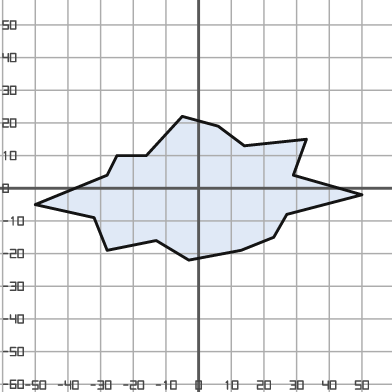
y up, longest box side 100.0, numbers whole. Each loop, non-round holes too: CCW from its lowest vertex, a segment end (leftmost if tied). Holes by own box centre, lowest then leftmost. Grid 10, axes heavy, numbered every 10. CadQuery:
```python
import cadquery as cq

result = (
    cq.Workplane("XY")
    .moveTo(-3.0, -22.0)
    .lineTo(13.0, -19.0)
    .lineTo(23.0, -15.0)
    .lineTo(27.0, -8.0)
    .lineTo(50.0, -2.0)
    .lineTo(29.0, 4.0)
    .lineTo(33.0, 15.0)
    .lineTo(14.0, 13.0)
    .lineTo(6.0, 19.0)
    .lineTo(-5.0, 22.0)
    .lineTo(-16.0, 10.0)
    .lineTo(-25.0, 10.0)
    .lineTo(-28.0, 4.0)
    .lineTo(-50.0, -5.0)
    .lineTo(-32.0, -9.0)
    .lineTo(-28.0, -19.0)
    .lineTo(-13.0, -16.0)
    .close()
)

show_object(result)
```